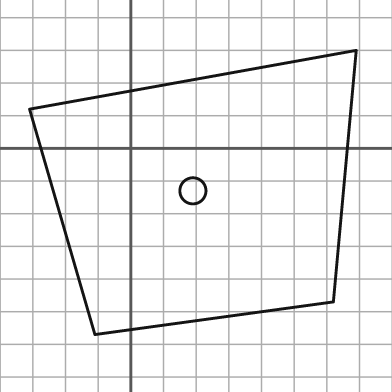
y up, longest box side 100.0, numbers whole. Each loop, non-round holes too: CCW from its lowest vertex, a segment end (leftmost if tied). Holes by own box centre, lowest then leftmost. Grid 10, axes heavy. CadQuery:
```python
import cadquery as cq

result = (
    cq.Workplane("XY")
    .moveTo(-11.0, -57.0)
    .lineTo(62.0, -47.0)
    .lineTo(69.0, 30.0)
    .lineTo(-31.0, 12.0)
    .close()
    .moveTo(19.0, -13.0)
    .circle(4.0)
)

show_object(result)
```